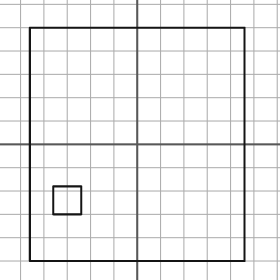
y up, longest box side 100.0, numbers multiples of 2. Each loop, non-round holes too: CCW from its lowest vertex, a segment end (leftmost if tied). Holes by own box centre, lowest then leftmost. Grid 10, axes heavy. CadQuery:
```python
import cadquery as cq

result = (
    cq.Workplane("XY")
    .moveTo(-46.0, -50.0)
    .lineTo(46.0, -50.0)
    .lineTo(46.0, 50.0)
    .lineTo(-46.0, 50.0)
    .close()
    .moveTo(-36.0, -30.0)
    .lineTo(-24.0, -30.0)
    .lineTo(-24.0, -18.0)
    .lineTo(-36.0, -18.0)
    .close()
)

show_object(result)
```